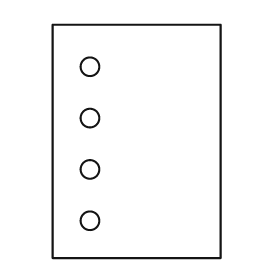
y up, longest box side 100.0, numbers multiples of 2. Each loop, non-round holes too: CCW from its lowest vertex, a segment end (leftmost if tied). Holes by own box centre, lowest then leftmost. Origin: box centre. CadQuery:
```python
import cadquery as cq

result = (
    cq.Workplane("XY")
    .moveTo(-36.0, -50.0)
    .lineTo(36.0, -50.0)
    .lineTo(36.0, 50.0)
    .lineTo(-36.0, 50.0)
    .close()
    .moveTo(-20.0, -34.0)
    .circle(4.0)
    .moveTo(-20.0, -12.0)
    .circle(4.0)
    .moveTo(-20.0, 10.0)
    .circle(4.0)
    .moveTo(-20.0, 32.0)
    .circle(4.0)
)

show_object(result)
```